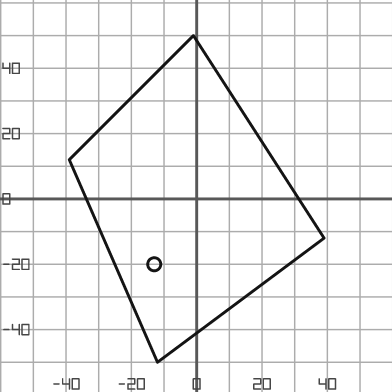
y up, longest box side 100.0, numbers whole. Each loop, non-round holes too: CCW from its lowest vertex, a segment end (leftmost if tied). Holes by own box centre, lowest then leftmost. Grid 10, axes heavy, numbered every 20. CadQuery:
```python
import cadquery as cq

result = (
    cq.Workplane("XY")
    .moveTo(-12.0, -50.0)
    .lineTo(39.0, -12.0)
    .lineTo(-1.0, 50.0)
    .lineTo(-39.0, 12.0)
    .close()
    .moveTo(-13.0, -20.0)
    .circle(2.0)
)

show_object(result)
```